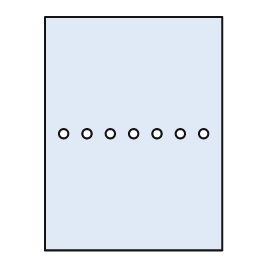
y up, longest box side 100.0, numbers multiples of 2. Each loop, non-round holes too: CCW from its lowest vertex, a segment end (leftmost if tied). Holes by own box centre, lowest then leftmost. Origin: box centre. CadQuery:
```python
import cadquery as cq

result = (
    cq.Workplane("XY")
    .moveTo(-38.0, -50.0)
    .lineTo(38.0, -50.0)
    .lineTo(38.0, 50.0)
    .lineTo(-38.0, 50.0)
    .close()
    .moveTo(-30.0, 0.0)
    .circle(2.0)
    .moveTo(-20.0, 0.0)
    .circle(2.0)
    .moveTo(-10.0, 0.0)
    .circle(2.0)
    .moveTo(0.0, 0.0)
    .circle(2.0)
    .moveTo(10.0, 0.0)
    .circle(2.0)
    .moveTo(20.0, 0.0)
    .circle(2.0)
    .moveTo(30.0, 0.0)
    .circle(2.0)
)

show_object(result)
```